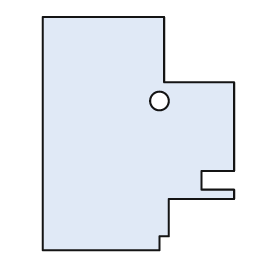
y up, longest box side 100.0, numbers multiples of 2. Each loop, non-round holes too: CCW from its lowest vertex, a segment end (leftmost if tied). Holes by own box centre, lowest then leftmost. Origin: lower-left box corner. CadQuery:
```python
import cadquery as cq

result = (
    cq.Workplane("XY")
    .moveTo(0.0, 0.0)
    .lineTo(50.0, 0.0)
    .lineTo(50.0, 6.0)
    .lineTo(54.0, 6.0)
    .lineTo(54.0, 22.0)
    .lineTo(82.0, 22.0)
    .lineTo(82.0, 26.0)
    .lineTo(68.0, 26.0)
    .lineTo(68.0, 34.0)
    .lineTo(82.0, 34.0)
    .lineTo(82.0, 72.0)
    .lineTo(52.0, 72.0)
    .lineTo(52.0, 100.0)
    .lineTo(0.0, 100.0)
    .close()
    .moveTo(50.0, 64.0)
    .circle(4.0)
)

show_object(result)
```